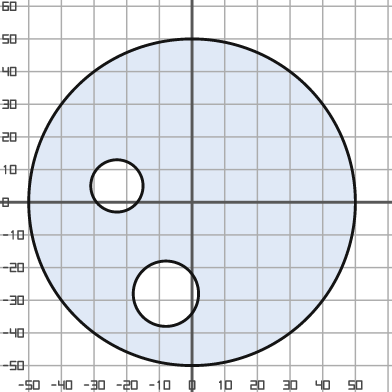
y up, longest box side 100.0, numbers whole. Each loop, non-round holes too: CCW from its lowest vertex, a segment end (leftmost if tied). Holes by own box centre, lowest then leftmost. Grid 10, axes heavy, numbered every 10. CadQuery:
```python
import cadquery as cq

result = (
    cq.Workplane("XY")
    .moveTo(0.0, 0.0)
    .circle(50.0)
    .moveTo(-8.0, -28.0)
    .circle(10.0)
    .moveTo(-23.0, 5.0)
    .circle(8.0)
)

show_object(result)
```